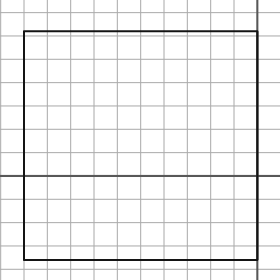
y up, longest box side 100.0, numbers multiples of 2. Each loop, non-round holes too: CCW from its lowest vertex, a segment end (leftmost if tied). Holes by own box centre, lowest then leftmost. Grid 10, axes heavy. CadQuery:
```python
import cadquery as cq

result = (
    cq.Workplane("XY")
    .moveTo(-100.0, -36.0)
    .lineTo(0.0, -36.0)
    .lineTo(0.0, 62.0)
    .lineTo(-100.0, 62.0)
    .close()
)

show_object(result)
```